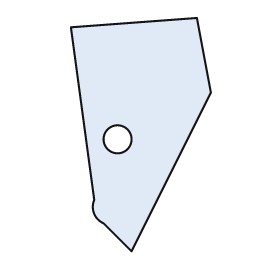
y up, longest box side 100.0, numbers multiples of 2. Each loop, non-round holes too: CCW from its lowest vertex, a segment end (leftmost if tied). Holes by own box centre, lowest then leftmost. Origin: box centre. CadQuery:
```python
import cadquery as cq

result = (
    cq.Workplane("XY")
    .moveTo(-4.0, -50.0)
    .lineTo(30.0, 18.0)
    .lineTo(24.0, 50.0)
    .lineTo(-30.0, 46.0)
    .lineTo(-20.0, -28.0)
    .threePointArc((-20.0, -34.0), (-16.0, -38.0))
    .close()
    .moveTo(-10.0, -2.0)
    .circle(6.0)
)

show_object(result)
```